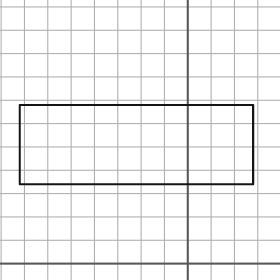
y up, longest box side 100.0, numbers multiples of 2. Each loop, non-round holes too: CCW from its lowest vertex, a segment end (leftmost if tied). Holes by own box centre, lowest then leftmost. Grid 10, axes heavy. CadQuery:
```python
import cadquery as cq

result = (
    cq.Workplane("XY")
    .moveTo(-72.0, 34.0)
    .lineTo(28.0, 34.0)
    .lineTo(28.0, 68.0)
    .lineTo(-72.0, 68.0)
    .close()
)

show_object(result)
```